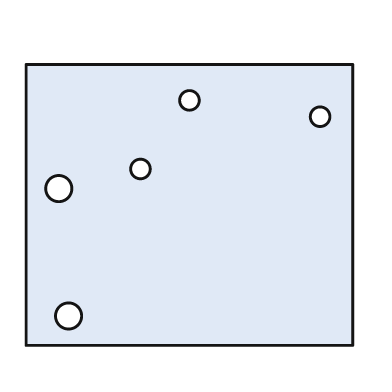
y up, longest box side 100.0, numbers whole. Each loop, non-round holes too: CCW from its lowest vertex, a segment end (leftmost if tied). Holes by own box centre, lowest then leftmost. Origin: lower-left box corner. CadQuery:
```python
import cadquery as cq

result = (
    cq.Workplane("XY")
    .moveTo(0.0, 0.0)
    .lineTo(100.0, 0.0)
    .lineTo(100.0, 86.0)
    .lineTo(0.0, 86.0)
    .close()
    .moveTo(13.0, 9.0)
    .circle(4.0)
    .moveTo(10.0, 48.0)
    .circle(4.0)
    .moveTo(35.0, 54.0)
    .circle(3.0)
    .moveTo(90.0, 70.0)
    .circle(3.0)
    .moveTo(50.0, 75.0)
    .circle(3.0)
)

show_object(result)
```